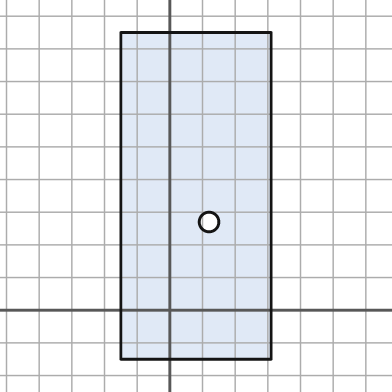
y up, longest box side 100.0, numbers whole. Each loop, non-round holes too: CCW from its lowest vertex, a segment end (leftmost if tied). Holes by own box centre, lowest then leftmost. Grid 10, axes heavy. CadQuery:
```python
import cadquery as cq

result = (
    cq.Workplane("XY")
    .moveTo(-15.0, -15.0)
    .lineTo(31.0, -15.0)
    .lineTo(31.0, 85.0)
    .lineTo(-15.0, 85.0)
    .close()
    .moveTo(12.0, 27.0)
    .circle(3.0)
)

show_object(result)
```